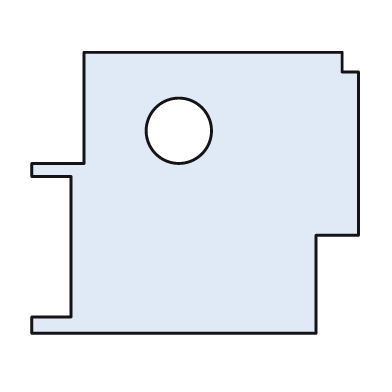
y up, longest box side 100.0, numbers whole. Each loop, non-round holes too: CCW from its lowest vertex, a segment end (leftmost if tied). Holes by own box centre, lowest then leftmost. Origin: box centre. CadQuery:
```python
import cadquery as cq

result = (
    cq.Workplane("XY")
    .moveTo(-50.0, -43.0)
    .lineTo(37.0, -43.0)
    .lineTo(37.0, -13.0)
    .lineTo(50.0, -13.0)
    .lineTo(50.0, 37.0)
    .lineTo(45.0, 37.0)
    .lineTo(45.0, 43.0)
    .lineTo(-34.0, 43.0)
    .lineTo(-34.0, 9.0)
    .lineTo(-50.0, 9.0)
    .lineTo(-50.0, 5.0)
    .lineTo(-38.0, 5.0)
    .lineTo(-38.0, -38.0)
    .lineTo(-50.0, -38.0)
    .close()
    .moveTo(-5.0, 19.0)
    .circle(10.0)
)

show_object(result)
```